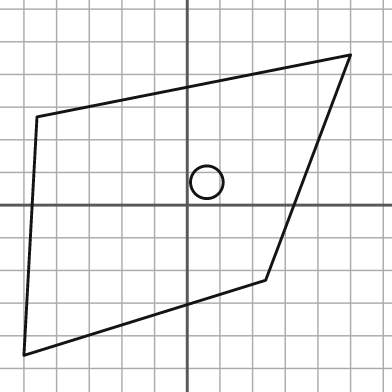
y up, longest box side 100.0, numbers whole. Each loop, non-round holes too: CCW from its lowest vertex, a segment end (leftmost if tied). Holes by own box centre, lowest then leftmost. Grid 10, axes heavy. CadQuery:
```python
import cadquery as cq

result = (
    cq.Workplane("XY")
    .moveTo(-50.0, -46.0)
    .lineTo(24.0, -23.0)
    .lineTo(50.0, 46.0)
    .lineTo(-46.0, 27.0)
    .close()
    .moveTo(6.0, 7.0)
    .circle(5.0)
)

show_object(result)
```